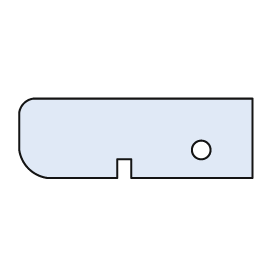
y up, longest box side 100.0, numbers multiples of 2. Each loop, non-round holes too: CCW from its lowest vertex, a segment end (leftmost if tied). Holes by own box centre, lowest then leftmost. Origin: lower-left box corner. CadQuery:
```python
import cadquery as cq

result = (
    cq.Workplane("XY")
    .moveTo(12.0, 0.0)
    .lineTo(42.0, 0.0)
    .lineTo(42.0, 8.0)
    .lineTo(48.0, 8.0)
    .lineTo(48.0, 0.0)
    .lineTo(100.0, 0.0)
    .lineTo(100.0, 34.0)
    .lineTo(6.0, 34.0)
    .threePointArc((2.0, 32.0), (0.0, 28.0))
    .lineTo(0.0, 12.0)
    .threePointArc((4.0, 4.0), (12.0, 0.0))
    .close()
    .moveTo(78.0, 12.0)
    .circle(4.0)
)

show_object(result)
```